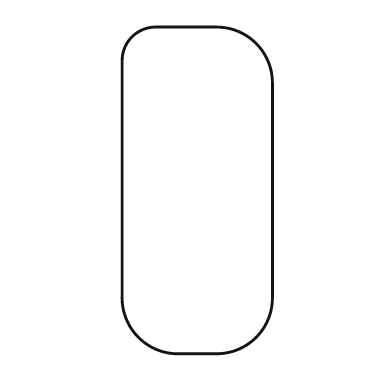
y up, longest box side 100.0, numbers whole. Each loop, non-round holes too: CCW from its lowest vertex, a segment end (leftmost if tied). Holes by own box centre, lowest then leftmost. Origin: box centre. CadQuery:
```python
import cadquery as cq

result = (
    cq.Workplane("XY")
    .moveTo(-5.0, -50.0)
    .lineTo(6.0, -50.0)
    .threePointArc((18.0, -45.0), (23.0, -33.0))
    .lineTo(23.0, 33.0)
    .threePointArc((18.0, 45.0), (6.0, 50.0))
    .lineTo(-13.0, 50.0)
    .threePointArc((-20.0, 47.0), (-23.0, 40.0))
    .lineTo(-23.0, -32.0)
    .threePointArc((-18.0, -45.0), (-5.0, -50.0))
    .close()
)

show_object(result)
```